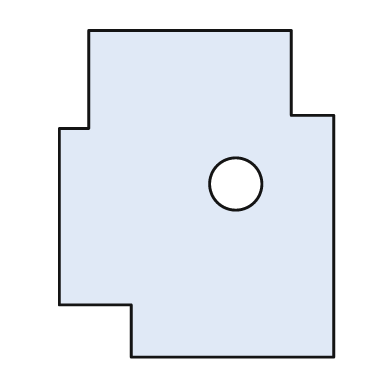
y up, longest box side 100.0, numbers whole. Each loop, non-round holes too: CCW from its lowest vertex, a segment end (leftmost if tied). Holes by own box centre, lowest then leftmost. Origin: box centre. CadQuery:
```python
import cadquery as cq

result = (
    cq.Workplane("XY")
    .moveTo(-20.0, -50.0)
    .lineTo(42.0, -50.0)
    .lineTo(42.0, 24.0)
    .lineTo(29.0, 24.0)
    .lineTo(29.0, 50.0)
    .lineTo(-33.0, 50.0)
    .lineTo(-33.0, 20.0)
    .lineTo(-42.0, 20.0)
    .lineTo(-42.0, -34.0)
    .lineTo(-20.0, -34.0)
    .close()
    .moveTo(12.0, 3.0)
    .circle(8.0)
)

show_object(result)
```